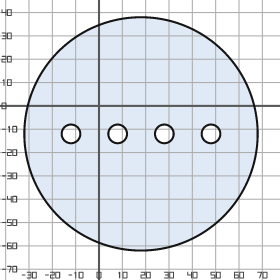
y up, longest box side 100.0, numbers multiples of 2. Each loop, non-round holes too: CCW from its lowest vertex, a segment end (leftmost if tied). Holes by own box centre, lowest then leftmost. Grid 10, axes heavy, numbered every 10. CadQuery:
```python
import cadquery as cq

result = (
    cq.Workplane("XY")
    .moveTo(18.0, -12.0)
    .circle(50.0)
    .moveTo(-12.0, -12.0)
    .circle(4.0)
    .moveTo(8.0, -12.0)
    .circle(4.0)
    .moveTo(28.0, -12.0)
    .circle(4.0)
    .moveTo(48.0, -12.0)
    .circle(4.0)
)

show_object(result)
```